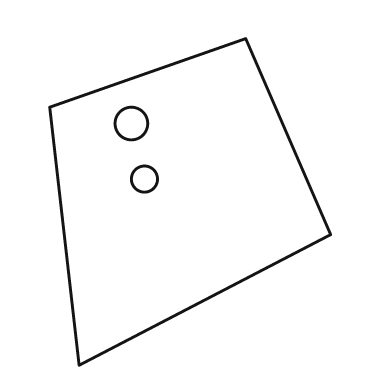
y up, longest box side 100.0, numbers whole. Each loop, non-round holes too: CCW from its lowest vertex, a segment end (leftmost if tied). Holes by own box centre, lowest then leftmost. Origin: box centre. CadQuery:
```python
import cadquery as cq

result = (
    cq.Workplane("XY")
    .moveTo(-34.0, -50.0)
    .lineTo(43.0, -10.0)
    .lineTo(17.0, 50.0)
    .lineTo(-43.0, 29.0)
    .close()
    .moveTo(-14.0, 7.0)
    .circle(4.0)
    .moveTo(-18.0, 24.0)
    .circle(5.0)
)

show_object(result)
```